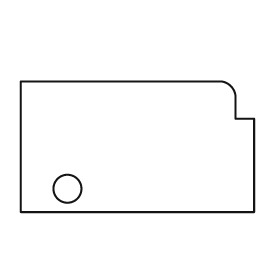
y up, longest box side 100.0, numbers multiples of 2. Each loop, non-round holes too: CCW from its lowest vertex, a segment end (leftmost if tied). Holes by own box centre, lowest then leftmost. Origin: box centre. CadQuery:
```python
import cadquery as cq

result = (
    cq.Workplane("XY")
    .moveTo(-50.0, -28.0)
    .lineTo(50.0, -28.0)
    .lineTo(50.0, 12.0)
    .lineTo(42.0, 12.0)
    .lineTo(42.0, 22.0)
    .threePointArc((40.0, 26.0), (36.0, 28.0))
    .lineTo(-50.0, 28.0)
    .close()
    .moveTo(-30.0, -18.0)
    .circle(6.0)
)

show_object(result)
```